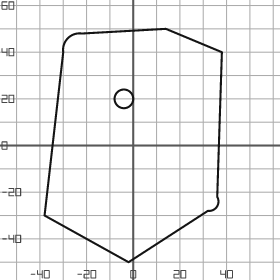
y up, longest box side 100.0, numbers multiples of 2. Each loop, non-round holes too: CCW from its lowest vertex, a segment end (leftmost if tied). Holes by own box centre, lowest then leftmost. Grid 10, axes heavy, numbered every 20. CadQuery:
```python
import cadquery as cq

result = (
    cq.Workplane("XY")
    .moveTo(-2.0, -50.0)
    .lineTo(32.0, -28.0)
    .threePointArc((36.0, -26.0), (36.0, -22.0))
    .lineTo(38.0, 40.0)
    .lineTo(14.0, 50.0)
    .lineTo(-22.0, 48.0)
    .threePointArc((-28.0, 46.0), (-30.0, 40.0))
    .lineTo(-38.0, -30.0)
    .close()
    .moveTo(-4.0, 20.0)
    .circle(4.0)
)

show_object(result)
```